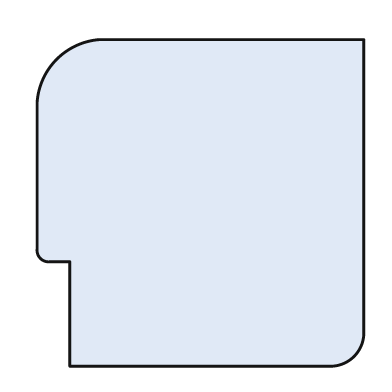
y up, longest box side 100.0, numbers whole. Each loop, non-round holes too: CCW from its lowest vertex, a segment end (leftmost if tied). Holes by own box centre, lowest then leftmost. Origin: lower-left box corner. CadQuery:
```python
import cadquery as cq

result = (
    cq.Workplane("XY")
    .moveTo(10.0, 0.0)
    .lineTo(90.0, 0.0)
    .threePointArc((97.0, 3.0), (100.0, 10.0))
    .lineTo(100.0, 100.0)
    .lineTo(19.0, 100.0)
    .threePointArc((6.0, 94.0), (0.0, 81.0))
    .lineTo(0.0, 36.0)
    .threePointArc((1.0, 33.0), (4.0, 32.0))
    .lineTo(10.0, 32.0)
    .close()
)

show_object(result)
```